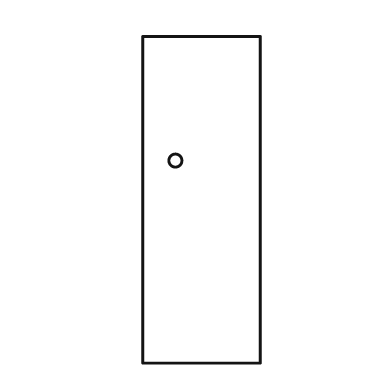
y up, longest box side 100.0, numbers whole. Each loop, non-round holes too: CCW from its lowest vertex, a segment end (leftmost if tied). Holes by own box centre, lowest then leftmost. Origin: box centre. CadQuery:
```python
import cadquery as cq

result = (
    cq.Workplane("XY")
    .moveTo(-18.0, -50.0)
    .lineTo(18.0, -50.0)
    .lineTo(18.0, 50.0)
    .lineTo(-18.0, 50.0)
    .close()
    .moveTo(-8.0, 12.0)
    .circle(2.0)
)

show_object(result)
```